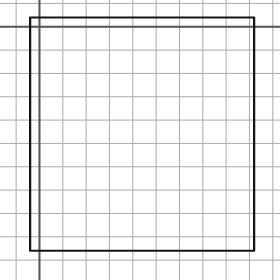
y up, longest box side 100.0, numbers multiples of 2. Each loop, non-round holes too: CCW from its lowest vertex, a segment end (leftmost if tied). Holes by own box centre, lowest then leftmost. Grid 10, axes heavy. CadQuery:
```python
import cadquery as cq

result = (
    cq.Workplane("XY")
    .moveTo(-4.0, -96.0)
    .lineTo(92.0, -96.0)
    .lineTo(92.0, 4.0)
    .lineTo(-4.0, 4.0)
    .close()
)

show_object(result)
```